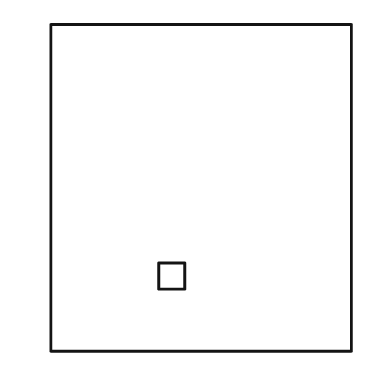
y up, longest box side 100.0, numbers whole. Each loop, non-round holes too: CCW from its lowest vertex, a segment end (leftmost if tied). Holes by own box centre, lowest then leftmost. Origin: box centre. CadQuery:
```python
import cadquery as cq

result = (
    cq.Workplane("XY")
    .moveTo(-46.0, -50.0)
    .lineTo(46.0, -50.0)
    .lineTo(46.0, 50.0)
    .lineTo(-46.0, 50.0)
    .close()
    .moveTo(-13.0, -31.0)
    .lineTo(-5.0, -31.0)
    .lineTo(-5.0, -23.0)
    .lineTo(-13.0, -23.0)
    .close()
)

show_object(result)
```